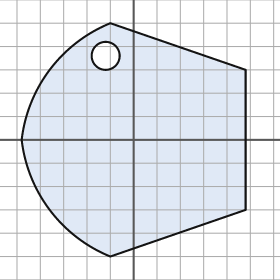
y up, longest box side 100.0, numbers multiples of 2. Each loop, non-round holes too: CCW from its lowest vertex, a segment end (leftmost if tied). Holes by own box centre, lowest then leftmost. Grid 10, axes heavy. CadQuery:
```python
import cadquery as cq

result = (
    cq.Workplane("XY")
    .moveTo(-10.0, -50.0)
    .lineTo(48.0, -30.0)
    .lineTo(48.0, 30.0)
    .lineTo(-10.0, 50.0)
    .threePointArc((-36.0, 30.0), (-48.0, 0.0))
    .threePointArc((-36.0, -30.0), (-10.0, -50.0))
    .close()
    .moveTo(-12.0, 36.0)
    .circle(6.0)
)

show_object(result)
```